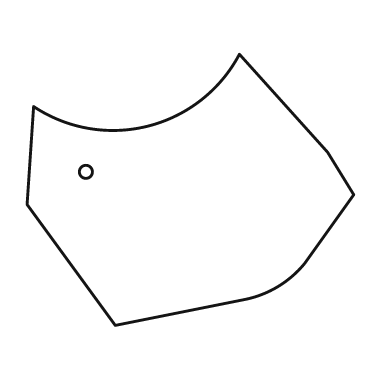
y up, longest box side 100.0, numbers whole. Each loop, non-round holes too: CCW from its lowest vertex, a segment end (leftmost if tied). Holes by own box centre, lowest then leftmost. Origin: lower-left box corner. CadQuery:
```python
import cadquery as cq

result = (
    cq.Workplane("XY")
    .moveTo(27.0, 0.0)
    .lineTo(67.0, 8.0)
    .threePointArc((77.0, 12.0), (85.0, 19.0))
    .lineTo(100.0, 40.0)
    .lineTo(92.0, 53.0)
    .lineTo(65.0, 83.0)
    .threePointArc((37.0, 61.0), (2.0, 67.0))
    .lineTo(0.0, 37.0)
    .close()
    .moveTo(18.0, 47.0)
    .circle(2.0)
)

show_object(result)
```